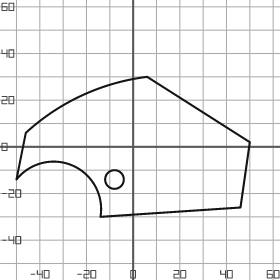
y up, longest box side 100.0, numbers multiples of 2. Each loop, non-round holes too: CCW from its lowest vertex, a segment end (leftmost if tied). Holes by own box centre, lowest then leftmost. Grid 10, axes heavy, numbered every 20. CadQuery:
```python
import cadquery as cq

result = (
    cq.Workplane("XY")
    .moveTo(-14.0, -30.0)
    .lineTo(46.0, -26.0)
    .lineTo(50.0, 2.0)
    .lineTo(6.0, 30.0)
    .threePointArc((-22.0, 22.0), (-46.0, 6.0))
    .lineTo(-50.0, -14.0)
    .threePointArc((-26.0, -8.0), (-14.0, -30.0))
    .close()
    .moveTo(-8.0, -14.0)
    .circle(4.0)
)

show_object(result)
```